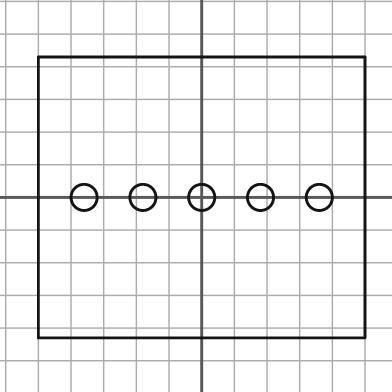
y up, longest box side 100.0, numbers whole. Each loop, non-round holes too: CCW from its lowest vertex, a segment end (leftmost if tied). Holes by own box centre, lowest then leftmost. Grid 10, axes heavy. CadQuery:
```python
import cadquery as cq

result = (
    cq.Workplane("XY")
    .moveTo(-50.0, -43.0)
    .lineTo(50.0, -43.0)
    .lineTo(50.0, 43.0)
    .lineTo(-50.0, 43.0)
    .close()
    .moveTo(-36.0, 0.0)
    .circle(4.0)
    .moveTo(-18.0, 0.0)
    .circle(4.0)
    .moveTo(0.0, 0.0)
    .circle(4.0)
    .moveTo(18.0, 0.0)
    .circle(4.0)
    .moveTo(36.0, 0.0)
    .circle(4.0)
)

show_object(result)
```